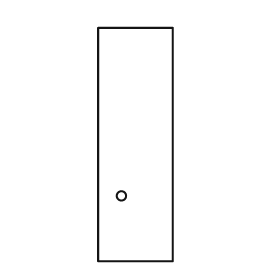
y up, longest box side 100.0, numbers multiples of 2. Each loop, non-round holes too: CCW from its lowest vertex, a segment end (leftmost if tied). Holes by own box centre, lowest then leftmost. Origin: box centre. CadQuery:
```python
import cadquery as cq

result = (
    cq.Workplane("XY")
    .moveTo(-16.0, -50.0)
    .lineTo(16.0, -50.0)
    .lineTo(16.0, 50.0)
    .lineTo(-16.0, 50.0)
    .close()
    .moveTo(-6.0, -22.0)
    .circle(2.0)
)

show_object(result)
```